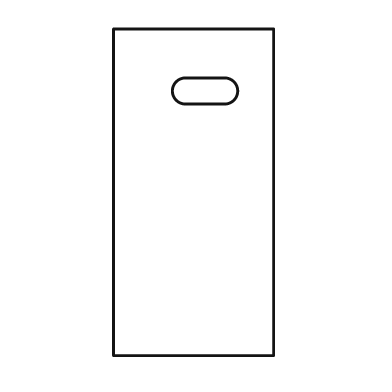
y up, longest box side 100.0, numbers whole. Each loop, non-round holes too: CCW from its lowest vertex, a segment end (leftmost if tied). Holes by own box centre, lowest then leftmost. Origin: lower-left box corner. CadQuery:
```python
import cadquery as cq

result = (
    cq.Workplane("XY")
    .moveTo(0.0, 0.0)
    .lineTo(49.0, 0.0)
    .lineTo(49.0, 100.0)
    .lineTo(0.0, 100.0)
    .close()
    .moveTo(22.0, 77.0)
    .lineTo(34.0, 77.0)
    .threePointArc((38.0, 81.0), (34.0, 85.0))
    .lineTo(22.0, 85.0)
    .threePointArc((18.0, 81.0), (22.0, 77.0))
    .close()
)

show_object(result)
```